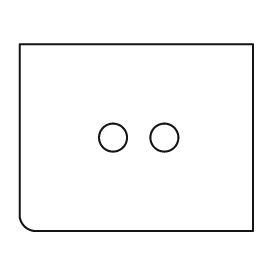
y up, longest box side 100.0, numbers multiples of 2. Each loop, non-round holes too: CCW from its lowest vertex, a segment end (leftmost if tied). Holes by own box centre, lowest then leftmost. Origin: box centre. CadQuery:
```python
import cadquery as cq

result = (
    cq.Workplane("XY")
    .moveTo(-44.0, -40.0)
    .lineTo(50.0, -40.0)
    .lineTo(50.0, 40.0)
    .lineTo(-50.0, 40.0)
    .lineTo(-50.0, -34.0)
    .threePointArc((-48.0, -38.0), (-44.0, -40.0))
    .close()
    .moveTo(-10.0, 0.0)
    .circle(6.0)
    .moveTo(12.0, 0.0)
    .circle(6.0)
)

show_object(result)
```